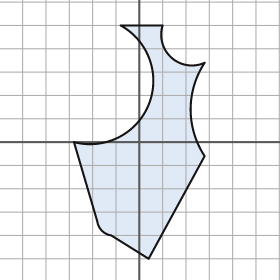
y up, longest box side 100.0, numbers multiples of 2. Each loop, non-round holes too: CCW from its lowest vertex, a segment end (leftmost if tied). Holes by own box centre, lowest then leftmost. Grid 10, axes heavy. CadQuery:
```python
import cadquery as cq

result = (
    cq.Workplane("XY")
    .moveTo(4.0, -50.0)
    .lineTo(28.0, -6.0)
    .threePointArc((22.0, 14.0), (28.0, 34.0))
    .threePointArc((14.0, 36.0), (10.0, 50.0))
    .lineTo(-8.0, 50.0)
    .threePointArc((4.0, 16.0), (-28.0, 0.0))
    .lineTo(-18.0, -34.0)
    .threePointArc((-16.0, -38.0), (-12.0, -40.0))
    .close()
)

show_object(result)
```